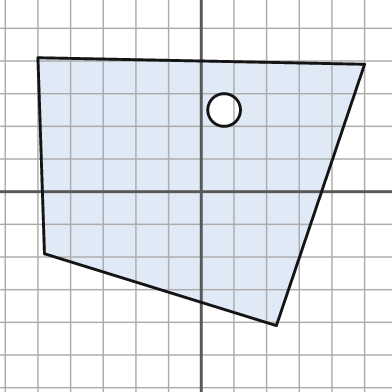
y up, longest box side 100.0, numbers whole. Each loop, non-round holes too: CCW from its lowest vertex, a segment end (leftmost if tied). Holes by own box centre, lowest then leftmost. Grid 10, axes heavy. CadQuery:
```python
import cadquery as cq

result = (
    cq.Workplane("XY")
    .moveTo(23.0, -41.0)
    .lineTo(50.0, 39.0)
    .lineTo(-50.0, 41.0)
    .lineTo(-48.0, -19.0)
    .close()
    .moveTo(7.0, 25.0)
    .circle(5.0)
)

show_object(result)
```